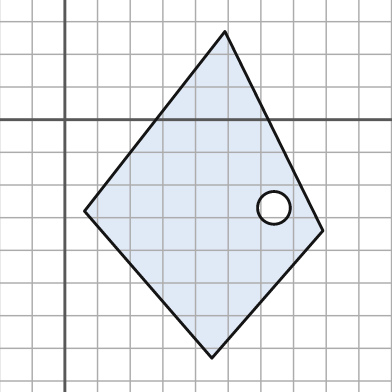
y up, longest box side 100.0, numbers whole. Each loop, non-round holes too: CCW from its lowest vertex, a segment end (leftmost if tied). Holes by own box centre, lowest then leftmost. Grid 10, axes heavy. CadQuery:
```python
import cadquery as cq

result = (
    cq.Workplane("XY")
    .moveTo(45.0, -73.0)
    .lineTo(79.0, -34.0)
    .lineTo(49.0, 27.0)
    .lineTo(6.0, -28.0)
    .close()
    .moveTo(64.0, -27.0)
    .circle(5.0)
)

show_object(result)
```